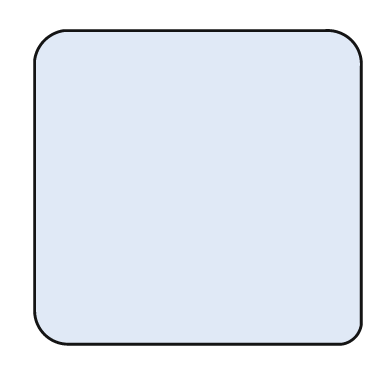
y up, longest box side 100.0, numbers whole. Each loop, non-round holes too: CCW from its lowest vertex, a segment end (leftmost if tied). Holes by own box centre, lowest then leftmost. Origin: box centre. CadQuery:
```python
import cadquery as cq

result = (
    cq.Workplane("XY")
    .moveTo(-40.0, -48.0)
    .lineTo(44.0, -48.0)
    .threePointArc((48.0, -46.0), (50.0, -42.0))
    .lineTo(50.0, 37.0)
    .threePointArc((47.0, 45.0), (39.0, 48.0))
    .lineTo(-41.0, 48.0)
    .threePointArc((-47.0, 45.0), (-50.0, 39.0))
    .lineTo(-50.0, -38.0)
    .threePointArc((-47.0, -45.0), (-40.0, -48.0))
    .close()
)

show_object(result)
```